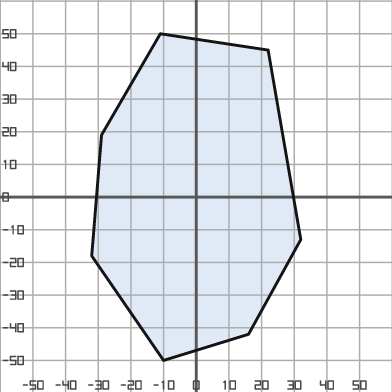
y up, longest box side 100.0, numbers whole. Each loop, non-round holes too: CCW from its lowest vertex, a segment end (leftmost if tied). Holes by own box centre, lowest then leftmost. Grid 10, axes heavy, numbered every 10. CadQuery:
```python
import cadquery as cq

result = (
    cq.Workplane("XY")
    .moveTo(-10.0, -50.0)
    .lineTo(16.0, -42.0)
    .lineTo(32.0, -13.0)
    .lineTo(22.0, 45.0)
    .lineTo(-11.0, 50.0)
    .lineTo(-29.0, 19.0)
    .lineTo(-32.0, -18.0)
    .close()
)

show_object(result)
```